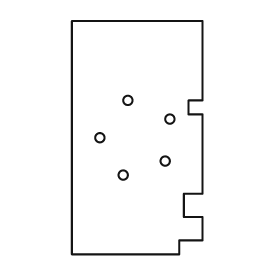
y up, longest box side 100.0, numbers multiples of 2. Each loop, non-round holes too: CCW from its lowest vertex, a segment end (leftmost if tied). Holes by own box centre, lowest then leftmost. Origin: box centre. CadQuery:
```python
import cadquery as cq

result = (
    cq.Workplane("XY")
    .moveTo(-28.0, -50.0)
    .lineTo(18.0, -50.0)
    .lineTo(18.0, -44.0)
    .lineTo(28.0, -44.0)
    .lineTo(28.0, -34.0)
    .lineTo(20.0, -34.0)
    .lineTo(20.0, -24.0)
    .lineTo(28.0, -24.0)
    .lineTo(28.0, 10.0)
    .lineTo(22.0, 10.0)
    .lineTo(22.0, 16.0)
    .lineTo(28.0, 16.0)
    .lineTo(28.0, 50.0)
    .lineTo(-28.0, 50.0)
    .close()
    .moveTo(-6.0, -16.0)
    .circle(2.0)
    .moveTo(12.0, -10.0)
    .circle(2.0)
    .moveTo(-16.0, 0.0)
    .circle(2.0)
    .moveTo(14.0, 8.0)
    .circle(2.0)
    .moveTo(-4.0, 16.0)
    .circle(2.0)
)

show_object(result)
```